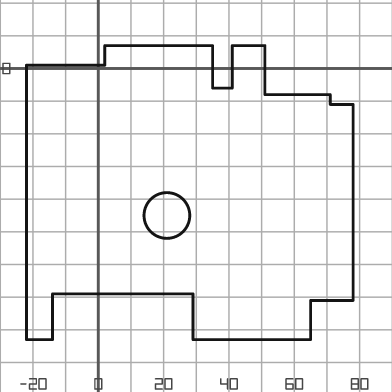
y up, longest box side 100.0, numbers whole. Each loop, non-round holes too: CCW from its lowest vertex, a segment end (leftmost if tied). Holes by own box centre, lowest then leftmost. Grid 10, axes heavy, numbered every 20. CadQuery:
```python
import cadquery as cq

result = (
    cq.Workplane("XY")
    .moveTo(-22.0, -83.0)
    .lineTo(-14.0, -83.0)
    .lineTo(-14.0, -69.0)
    .lineTo(29.0, -69.0)
    .lineTo(29.0, -83.0)
    .lineTo(65.0, -83.0)
    .lineTo(65.0, -71.0)
    .lineTo(78.0, -71.0)
    .lineTo(78.0, -11.0)
    .lineTo(71.0, -11.0)
    .lineTo(71.0, -8.0)
    .lineTo(51.0, -8.0)
    .lineTo(51.0, 7.0)
    .lineTo(41.0, 7.0)
    .lineTo(41.0, -6.0)
    .lineTo(35.0, -6.0)
    .lineTo(35.0, 7.0)
    .lineTo(2.0, 7.0)
    .lineTo(2.0, 1.0)
    .lineTo(-22.0, 1.0)
    .close()
    .moveTo(21.0, -45.0)
    .circle(7.0)
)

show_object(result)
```